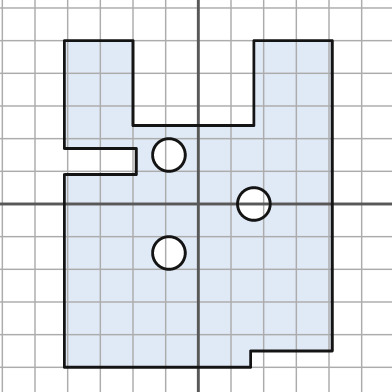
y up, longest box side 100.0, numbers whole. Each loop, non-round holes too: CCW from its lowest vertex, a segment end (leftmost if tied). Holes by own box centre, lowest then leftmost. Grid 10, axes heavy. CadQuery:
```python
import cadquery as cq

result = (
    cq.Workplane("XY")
    .moveTo(-41.0, -50.0)
    .lineTo(16.0, -50.0)
    .lineTo(16.0, -45.0)
    .lineTo(41.0, -45.0)
    .lineTo(41.0, 50.0)
    .lineTo(17.0, 50.0)
    .lineTo(17.0, 24.0)
    .lineTo(-20.0, 24.0)
    .lineTo(-20.0, 50.0)
    .lineTo(-41.0, 50.0)
    .lineTo(-41.0, 17.0)
    .lineTo(-19.0, 17.0)
    .lineTo(-19.0, 9.0)
    .lineTo(-41.0, 9.0)
    .close()
    .moveTo(-9.0, -15.0)
    .circle(5.0)
    .moveTo(17.0, 0.0)
    .circle(5.0)
    .moveTo(-9.0, 15.0)
    .circle(5.0)
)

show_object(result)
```